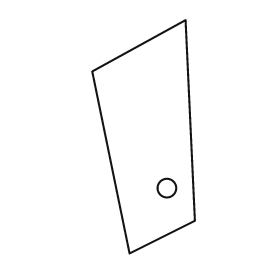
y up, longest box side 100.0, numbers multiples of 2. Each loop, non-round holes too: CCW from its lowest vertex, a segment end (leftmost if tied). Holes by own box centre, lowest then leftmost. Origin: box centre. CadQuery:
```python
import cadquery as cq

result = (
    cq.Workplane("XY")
    .moveTo(-6.0, -50.0)
    .lineTo(22.0, -36.0)
    .lineTo(18.0, 50.0)
    .lineTo(-22.0, 28.0)
    .close()
    .moveTo(10.0, -22.0)
    .circle(4.0)
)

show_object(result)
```